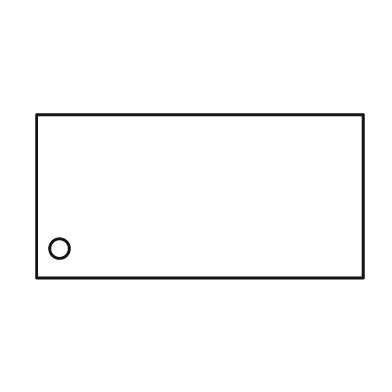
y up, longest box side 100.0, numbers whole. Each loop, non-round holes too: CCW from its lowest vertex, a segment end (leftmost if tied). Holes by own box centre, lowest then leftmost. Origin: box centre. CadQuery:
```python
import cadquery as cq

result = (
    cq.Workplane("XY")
    .moveTo(-50.0, -25.0)
    .lineTo(50.0, -25.0)
    .lineTo(50.0, 25.0)
    .lineTo(-50.0, 25.0)
    .close()
    .moveTo(-43.0, -16.0)
    .circle(3.0)
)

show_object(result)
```